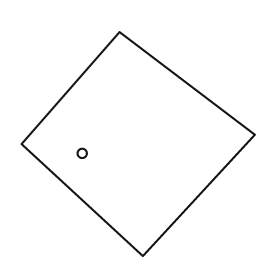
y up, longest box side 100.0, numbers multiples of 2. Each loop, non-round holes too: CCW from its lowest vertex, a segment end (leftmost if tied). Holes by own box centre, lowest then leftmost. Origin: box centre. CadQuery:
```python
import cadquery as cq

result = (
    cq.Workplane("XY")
    .moveTo(2.0, -48.0)
    .lineTo(50.0, 4.0)
    .lineTo(-8.0, 48.0)
    .lineTo(-50.0, 0.0)
    .close()
    .moveTo(-24.0, -4.0)
    .circle(2.0)
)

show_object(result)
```